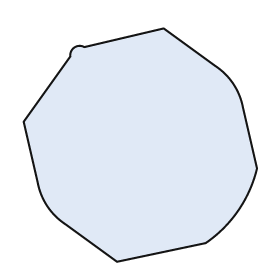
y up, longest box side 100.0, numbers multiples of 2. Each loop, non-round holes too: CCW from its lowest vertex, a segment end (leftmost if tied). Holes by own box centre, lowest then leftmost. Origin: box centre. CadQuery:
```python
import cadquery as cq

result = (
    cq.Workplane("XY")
    .moveTo(-10.0, -50.0)
    .lineTo(28.0, -42.0)
    .threePointArc((42.0, -28.0), (50.0, -10.0))
    .lineTo(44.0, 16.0)
    .threePointArc((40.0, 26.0), (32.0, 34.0))
    .lineTo(10.0, 50.0)
    .lineTo(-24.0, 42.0)
    .threePointArc((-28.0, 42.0), (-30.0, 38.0))
    .lineTo(-50.0, 10.0)
    .lineTo(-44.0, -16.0)
    .threePointArc((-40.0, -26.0), (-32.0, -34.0))
    .close()
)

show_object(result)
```